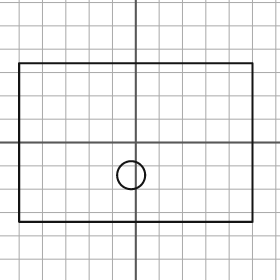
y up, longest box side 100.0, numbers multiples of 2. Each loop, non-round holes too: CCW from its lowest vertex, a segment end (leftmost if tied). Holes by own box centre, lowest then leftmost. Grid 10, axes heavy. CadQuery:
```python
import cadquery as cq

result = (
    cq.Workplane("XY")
    .moveTo(-50.0, -34.0)
    .lineTo(50.0, -34.0)
    .lineTo(50.0, 34.0)
    .lineTo(-50.0, 34.0)
    .close()
    .moveTo(-2.0, -14.0)
    .circle(6.0)
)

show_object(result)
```